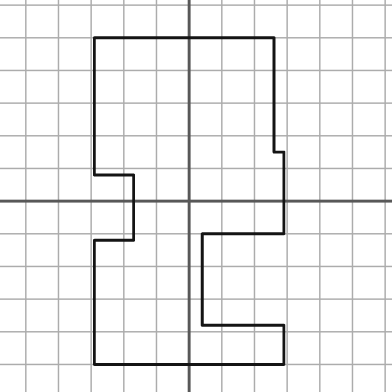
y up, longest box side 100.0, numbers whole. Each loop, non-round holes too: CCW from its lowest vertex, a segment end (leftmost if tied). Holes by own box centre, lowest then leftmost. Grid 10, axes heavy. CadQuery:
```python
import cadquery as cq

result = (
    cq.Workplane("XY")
    .moveTo(-29.0, -50.0)
    .lineTo(29.0, -50.0)
    .lineTo(29.0, -38.0)
    .lineTo(4.0, -38.0)
    .lineTo(4.0, -10.0)
    .lineTo(29.0, -10.0)
    .lineTo(29.0, 15.0)
    .lineTo(26.0, 15.0)
    .lineTo(26.0, 50.0)
    .lineTo(-29.0, 50.0)
    .lineTo(-29.0, 8.0)
    .lineTo(-17.0, 8.0)
    .lineTo(-17.0, -12.0)
    .lineTo(-29.0, -12.0)
    .close()
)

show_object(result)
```